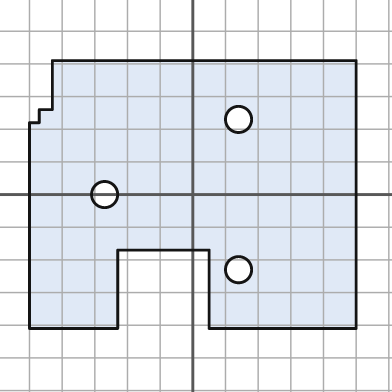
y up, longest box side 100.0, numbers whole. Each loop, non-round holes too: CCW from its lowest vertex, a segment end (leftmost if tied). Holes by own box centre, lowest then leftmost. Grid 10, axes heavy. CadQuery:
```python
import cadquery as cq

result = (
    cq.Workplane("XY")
    .moveTo(-50.0, -41.0)
    .lineTo(-23.0, -41.0)
    .lineTo(-23.0, -17.0)
    .lineTo(5.0, -17.0)
    .lineTo(5.0, -41.0)
    .lineTo(50.0, -41.0)
    .lineTo(50.0, 41.0)
    .lineTo(-43.0, 41.0)
    .lineTo(-43.0, 26.0)
    .lineTo(-47.0, 26.0)
    .lineTo(-47.0, 22.0)
    .lineTo(-50.0, 22.0)
    .close()
    .moveTo(14.0, -23.0)
    .circle(4.0)
    .moveTo(-27.0, 0.0)
    .circle(4.0)
    .moveTo(14.0, 23.0)
    .circle(4.0)
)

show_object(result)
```